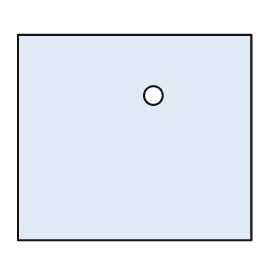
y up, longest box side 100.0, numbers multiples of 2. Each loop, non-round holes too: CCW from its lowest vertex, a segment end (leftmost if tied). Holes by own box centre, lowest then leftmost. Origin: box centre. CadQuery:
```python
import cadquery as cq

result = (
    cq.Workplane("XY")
    .moveTo(-50.0, -44.0)
    .lineTo(50.0, -44.0)
    .lineTo(50.0, 44.0)
    .lineTo(-50.0, 44.0)
    .close()
    .moveTo(8.0, 18.0)
    .circle(4.0)
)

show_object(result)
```